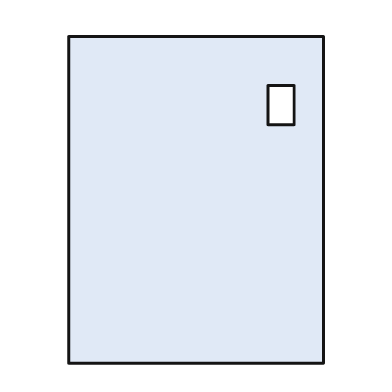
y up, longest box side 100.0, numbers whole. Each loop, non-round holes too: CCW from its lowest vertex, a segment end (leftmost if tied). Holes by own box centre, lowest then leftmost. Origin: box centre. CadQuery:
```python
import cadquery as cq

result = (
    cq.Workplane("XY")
    .moveTo(-39.0, -50.0)
    .lineTo(39.0, -50.0)
    .lineTo(39.0, 50.0)
    .lineTo(-39.0, 50.0)
    .close()
    .moveTo(22.0, 23.0)
    .lineTo(30.0, 23.0)
    .lineTo(30.0, 35.0)
    .lineTo(22.0, 35.0)
    .close()
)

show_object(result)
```